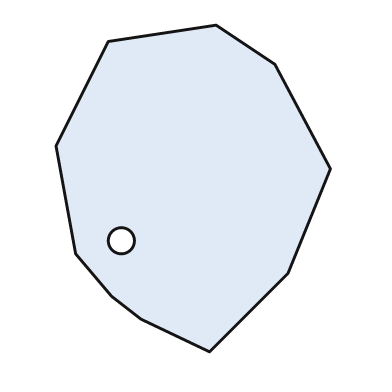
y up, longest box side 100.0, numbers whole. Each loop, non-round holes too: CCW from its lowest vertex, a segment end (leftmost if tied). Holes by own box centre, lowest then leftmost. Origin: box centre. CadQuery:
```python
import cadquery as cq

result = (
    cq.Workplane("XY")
    .moveTo(5.0, -50.0)
    .lineTo(29.0, -26.0)
    .lineTo(42.0, 6.0)
    .lineTo(25.0, 38.0)
    .lineTo(7.0, 50.0)
    .lineTo(-26.0, 45.0)
    .lineTo(-42.0, 13.0)
    .lineTo(-36.0, -20.0)
    .lineTo(-25.0, -33.0)
    .lineTo(-16.0, -40.0)
    .close()
    .moveTo(-22.0, -16.0)
    .circle(4.0)
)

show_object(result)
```